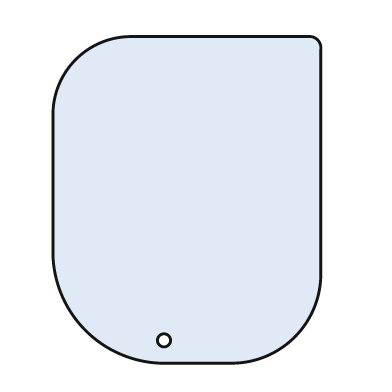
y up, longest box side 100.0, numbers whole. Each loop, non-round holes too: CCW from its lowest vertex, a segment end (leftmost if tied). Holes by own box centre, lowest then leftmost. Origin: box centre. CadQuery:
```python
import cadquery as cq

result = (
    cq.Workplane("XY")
    .moveTo(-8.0, -50.0)
    .lineTo(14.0, -50.0)
    .threePointArc((33.0, -42.0), (41.0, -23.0))
    .lineTo(41.0, 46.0)
    .threePointArc((40.0, 49.0), (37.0, 50.0))
    .lineTo(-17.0, 50.0)
    .threePointArc((-34.0, 43.0), (-41.0, 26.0))
    .lineTo(-41.0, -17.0)
    .threePointArc((-31.0, -40.0), (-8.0, -50.0))
    .close()
    .moveTo(-7.0, -43.0)
    .circle(2.0)
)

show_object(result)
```